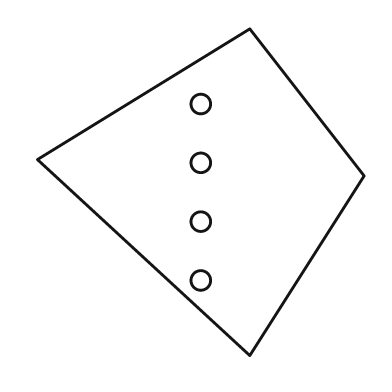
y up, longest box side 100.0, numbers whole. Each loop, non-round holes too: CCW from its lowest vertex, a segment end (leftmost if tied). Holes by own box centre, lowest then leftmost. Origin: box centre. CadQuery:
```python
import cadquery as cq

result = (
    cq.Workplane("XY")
    .moveTo(15.0, -50.0)
    .lineTo(50.0, 5.0)
    .lineTo(15.0, 50.0)
    .lineTo(-50.0, 10.0)
    .close()
    .moveTo(0.0, -27.0)
    .circle(3.0)
    .moveTo(0.0, -9.0)
    .circle(3.0)
    .moveTo(0.0, 9.0)
    .circle(3.0)
    .moveTo(0.0, 27.0)
    .circle(3.0)
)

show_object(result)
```